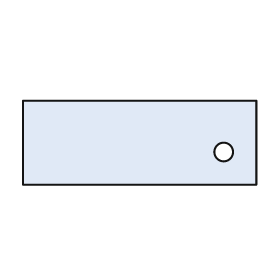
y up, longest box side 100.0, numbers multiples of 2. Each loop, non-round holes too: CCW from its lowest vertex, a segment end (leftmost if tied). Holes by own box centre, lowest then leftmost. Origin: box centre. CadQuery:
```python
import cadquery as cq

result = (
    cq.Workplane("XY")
    .moveTo(-50.0, -18.0)
    .lineTo(50.0, -18.0)
    .lineTo(50.0, 18.0)
    .lineTo(-50.0, 18.0)
    .close()
    .moveTo(36.0, -4.0)
    .circle(4.0)
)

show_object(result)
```